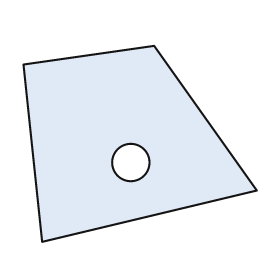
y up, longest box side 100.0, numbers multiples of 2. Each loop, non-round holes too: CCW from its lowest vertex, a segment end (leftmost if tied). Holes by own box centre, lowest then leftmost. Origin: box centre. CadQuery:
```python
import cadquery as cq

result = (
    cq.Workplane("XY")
    .moveTo(-42.0, -42.0)
    .lineTo(50.0, -20.0)
    .lineTo(6.0, 42.0)
    .lineTo(-50.0, 34.0)
    .close()
    .moveTo(-4.0, -8.0)
    .circle(8.0)
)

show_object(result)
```